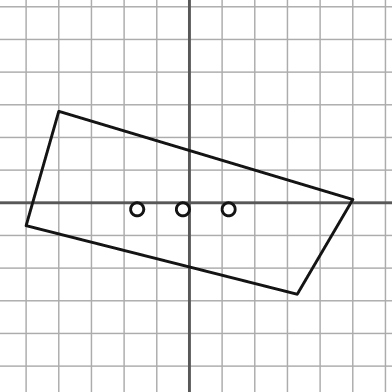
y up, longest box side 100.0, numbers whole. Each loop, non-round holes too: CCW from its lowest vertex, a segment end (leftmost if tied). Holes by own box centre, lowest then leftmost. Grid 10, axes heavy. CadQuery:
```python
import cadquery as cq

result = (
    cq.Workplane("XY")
    .moveTo(33.0, -28.0)
    .lineTo(50.0, 1.0)
    .lineTo(-40.0, 28.0)
    .lineTo(-50.0, -7.0)
    .close()
    .moveTo(-16.0, -2.0)
    .circle(2.0)
    .moveTo(-2.0, -2.0)
    .circle(2.0)
    .moveTo(12.0, -2.0)
    .circle(2.0)
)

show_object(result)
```